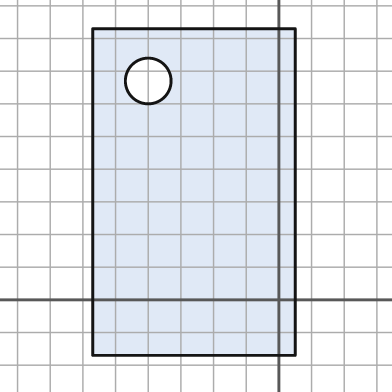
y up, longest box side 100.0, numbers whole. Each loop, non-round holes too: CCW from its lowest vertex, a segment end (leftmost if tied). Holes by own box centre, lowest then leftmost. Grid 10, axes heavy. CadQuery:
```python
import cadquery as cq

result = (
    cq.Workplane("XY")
    .moveTo(-57.0, -17.0)
    .lineTo(5.0, -17.0)
    .lineTo(5.0, 83.0)
    .lineTo(-57.0, 83.0)
    .close()
    .moveTo(-40.0, 67.0)
    .circle(7.0)
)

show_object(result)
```